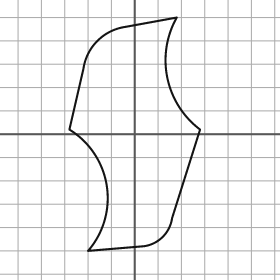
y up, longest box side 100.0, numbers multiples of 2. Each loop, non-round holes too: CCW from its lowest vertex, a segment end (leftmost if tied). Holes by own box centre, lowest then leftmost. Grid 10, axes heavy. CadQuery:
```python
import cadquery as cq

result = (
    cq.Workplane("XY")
    .moveTo(-20.0, -50.0)
    .lineTo(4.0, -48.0)
    .threePointArc((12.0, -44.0), (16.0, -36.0))
    .lineTo(28.0, 2.0)
    .threePointArc((14.0, 24.0), (18.0, 50.0))
    .lineTo(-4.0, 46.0)
    .threePointArc((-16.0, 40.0), (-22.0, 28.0))
    .lineTo(-28.0, 2.0)
    .threePointArc((-12.0, -22.0), (-20.0, -50.0))
    .close()
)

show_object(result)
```